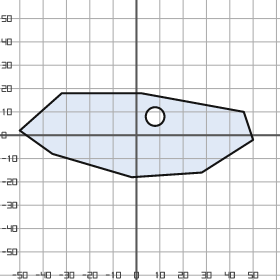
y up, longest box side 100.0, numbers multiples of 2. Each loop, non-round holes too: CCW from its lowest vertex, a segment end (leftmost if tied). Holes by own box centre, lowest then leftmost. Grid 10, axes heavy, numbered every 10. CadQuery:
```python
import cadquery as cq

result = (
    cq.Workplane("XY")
    .moveTo(-2.0, -18.0)
    .lineTo(28.0, -16.0)
    .lineTo(50.0, -2.0)
    .lineTo(46.0, 10.0)
    .lineTo(2.0, 18.0)
    .lineTo(-32.0, 18.0)
    .lineTo(-50.0, 2.0)
    .lineTo(-36.0, -8.0)
    .close()
    .moveTo(8.0, 8.0)
    .circle(4.0)
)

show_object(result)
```